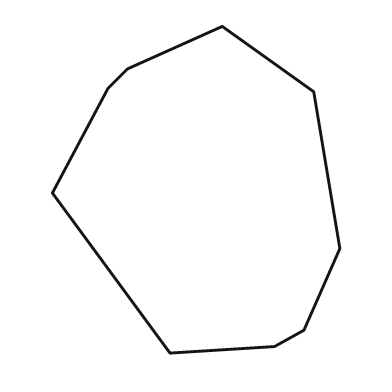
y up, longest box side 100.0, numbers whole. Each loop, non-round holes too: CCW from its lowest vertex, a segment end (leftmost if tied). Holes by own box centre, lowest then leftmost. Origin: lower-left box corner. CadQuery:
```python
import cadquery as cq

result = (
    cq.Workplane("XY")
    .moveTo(36.0, 0.0)
    .lineTo(68.0, 2.0)
    .lineTo(77.0, 7.0)
    .lineTo(88.0, 32.0)
    .lineTo(80.0, 80.0)
    .lineTo(52.0, 100.0)
    .lineTo(23.0, 87.0)
    .lineTo(17.0, 81.0)
    .lineTo(0.0, 49.0)
    .close()
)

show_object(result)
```